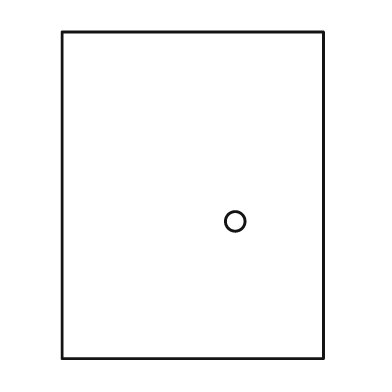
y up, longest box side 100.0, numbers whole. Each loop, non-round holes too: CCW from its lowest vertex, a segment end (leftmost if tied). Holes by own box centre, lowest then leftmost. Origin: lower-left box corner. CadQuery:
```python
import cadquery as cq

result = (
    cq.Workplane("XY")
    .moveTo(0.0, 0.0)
    .lineTo(80.0, 0.0)
    .lineTo(80.0, 100.0)
    .lineTo(0.0, 100.0)
    .close()
    .moveTo(53.0, 42.0)
    .circle(3.0)
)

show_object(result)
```